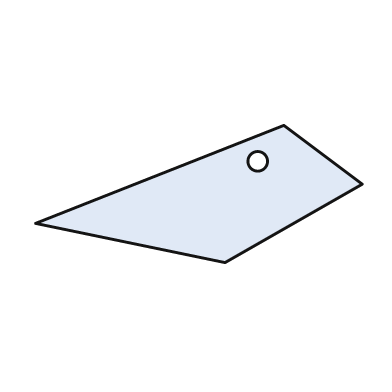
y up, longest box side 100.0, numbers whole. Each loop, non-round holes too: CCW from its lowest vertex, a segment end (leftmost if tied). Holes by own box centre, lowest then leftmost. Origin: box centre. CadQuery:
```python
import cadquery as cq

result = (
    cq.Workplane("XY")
    .moveTo(8.0, -21.0)
    .lineTo(50.0, 3.0)
    .lineTo(26.0, 21.0)
    .lineTo(-50.0, -9.0)
    .close()
    .moveTo(18.0, 10.0)
    .circle(3.0)
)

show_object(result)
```